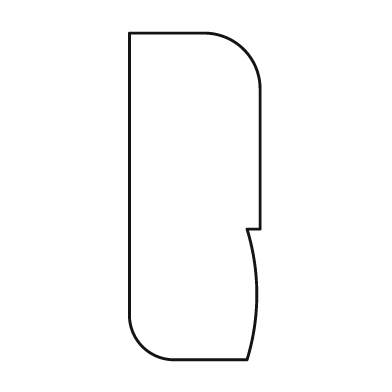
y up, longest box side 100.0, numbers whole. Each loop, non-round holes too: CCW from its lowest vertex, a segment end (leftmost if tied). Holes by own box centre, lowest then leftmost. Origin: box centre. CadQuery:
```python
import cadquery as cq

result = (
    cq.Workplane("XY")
    .moveTo(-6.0, -50.0)
    .lineTo(16.0, -50.0)
    .threePointArc((19.0, -30.0), (16.0, -10.0))
    .lineTo(20.0, -10.0)
    .lineTo(20.0, 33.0)
    .threePointArc((15.0, 45.0), (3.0, 50.0))
    .lineTo(-20.0, 50.0)
    .lineTo(-20.0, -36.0)
    .threePointArc((-16.0, -46.0), (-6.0, -50.0))
    .close()
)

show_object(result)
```